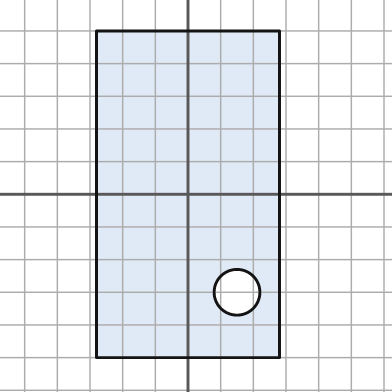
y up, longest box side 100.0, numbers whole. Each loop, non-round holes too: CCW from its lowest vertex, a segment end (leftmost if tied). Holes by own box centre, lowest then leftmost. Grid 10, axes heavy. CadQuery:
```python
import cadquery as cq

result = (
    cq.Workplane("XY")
    .moveTo(-28.0, -50.0)
    .lineTo(28.0, -50.0)
    .lineTo(28.0, 50.0)
    .lineTo(-28.0, 50.0)
    .close()
    .moveTo(15.0, -30.0)
    .circle(7.0)
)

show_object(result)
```